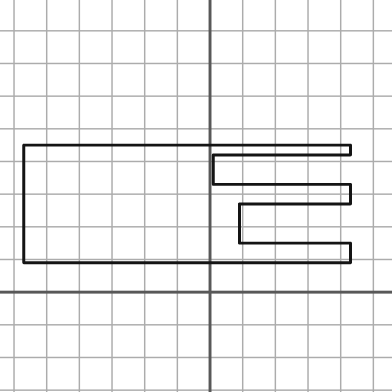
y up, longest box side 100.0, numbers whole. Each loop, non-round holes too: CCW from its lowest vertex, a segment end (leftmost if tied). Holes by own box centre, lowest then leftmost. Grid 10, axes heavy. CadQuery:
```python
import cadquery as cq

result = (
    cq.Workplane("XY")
    .moveTo(-57.0, 9.0)
    .lineTo(43.0, 9.0)
    .lineTo(43.0, 15.0)
    .lineTo(9.0, 15.0)
    .lineTo(9.0, 27.0)
    .lineTo(43.0, 27.0)
    .lineTo(43.0, 33.0)
    .lineTo(1.0, 33.0)
    .lineTo(1.0, 42.0)
    .lineTo(43.0, 42.0)
    .lineTo(43.0, 45.0)
    .lineTo(-57.0, 45.0)
    .close()
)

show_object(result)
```